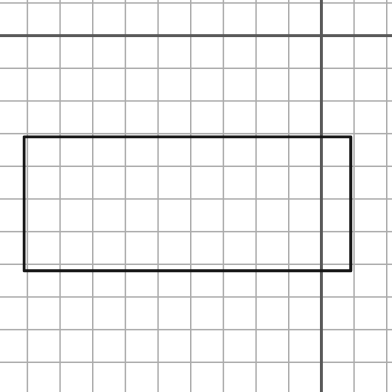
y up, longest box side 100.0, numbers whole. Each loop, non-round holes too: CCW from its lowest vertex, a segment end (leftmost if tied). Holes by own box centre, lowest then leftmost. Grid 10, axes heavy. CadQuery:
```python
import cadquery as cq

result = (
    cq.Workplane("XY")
    .moveTo(-91.0, -72.0)
    .lineTo(9.0, -72.0)
    .lineTo(9.0, -31.0)
    .lineTo(-91.0, -31.0)
    .close()
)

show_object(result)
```